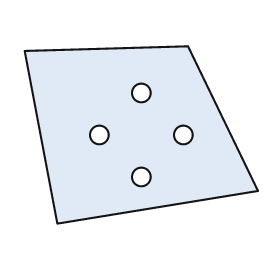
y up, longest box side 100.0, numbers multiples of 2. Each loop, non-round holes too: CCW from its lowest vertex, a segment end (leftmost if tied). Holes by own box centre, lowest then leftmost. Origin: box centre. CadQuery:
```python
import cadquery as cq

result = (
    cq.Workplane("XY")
    .moveTo(-36.0, -38.0)
    .lineTo(50.0, -24.0)
    .lineTo(20.0, 38.0)
    .lineTo(-50.0, 36.0)
    .close()
    .moveTo(0.0, -18.0)
    .circle(4.0)
    .moveTo(-18.0, 0.0)
    .circle(4.0)
    .moveTo(18.0, 0.0)
    .circle(4.0)
    .moveTo(0.0, 18.0)
    .circle(4.0)
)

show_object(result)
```